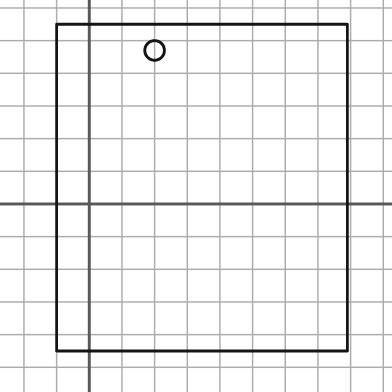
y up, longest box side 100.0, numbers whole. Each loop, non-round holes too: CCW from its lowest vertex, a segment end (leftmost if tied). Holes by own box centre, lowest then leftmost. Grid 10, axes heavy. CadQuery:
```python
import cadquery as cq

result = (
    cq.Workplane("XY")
    .moveTo(-10.0, -45.0)
    .lineTo(79.0, -45.0)
    .lineTo(79.0, 55.0)
    .lineTo(-10.0, 55.0)
    .close()
    .moveTo(20.0, 47.0)
    .circle(3.0)
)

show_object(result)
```